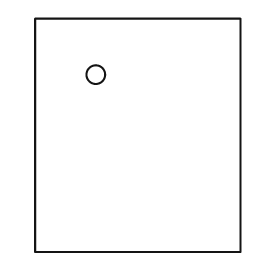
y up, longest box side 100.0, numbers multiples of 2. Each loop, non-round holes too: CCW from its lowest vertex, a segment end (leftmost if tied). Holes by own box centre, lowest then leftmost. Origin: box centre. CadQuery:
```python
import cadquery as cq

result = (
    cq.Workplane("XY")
    .moveTo(-44.0, -50.0)
    .lineTo(44.0, -50.0)
    .lineTo(44.0, 50.0)
    .lineTo(-44.0, 50.0)
    .close()
    .moveTo(-18.0, 26.0)
    .circle(4.0)
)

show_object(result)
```